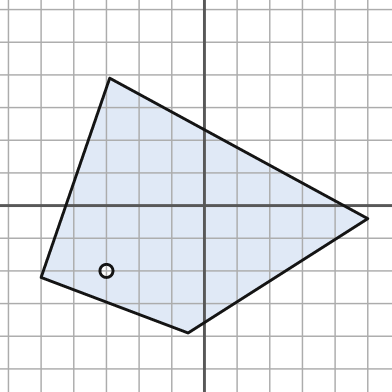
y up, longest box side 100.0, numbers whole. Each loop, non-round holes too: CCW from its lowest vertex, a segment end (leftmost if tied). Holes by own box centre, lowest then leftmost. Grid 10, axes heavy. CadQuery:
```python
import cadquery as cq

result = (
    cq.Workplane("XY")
    .moveTo(-5.0, -39.0)
    .lineTo(50.0, -4.0)
    .lineTo(-29.0, 39.0)
    .lineTo(-50.0, -22.0)
    .close()
    .moveTo(-30.0, -20.0)
    .circle(2.0)
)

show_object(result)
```